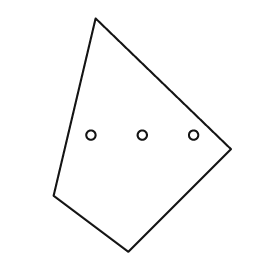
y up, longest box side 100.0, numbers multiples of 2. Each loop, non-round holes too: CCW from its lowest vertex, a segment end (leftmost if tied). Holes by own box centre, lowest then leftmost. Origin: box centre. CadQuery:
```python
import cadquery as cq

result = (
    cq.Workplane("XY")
    .moveTo(-6.0, -50.0)
    .lineTo(38.0, -6.0)
    .lineTo(-20.0, 50.0)
    .lineTo(-38.0, -26.0)
    .close()
    .moveTo(-22.0, 0.0)
    .circle(2.0)
    .moveTo(0.0, 0.0)
    .circle(2.0)
    .moveTo(22.0, 0.0)
    .circle(2.0)
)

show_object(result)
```